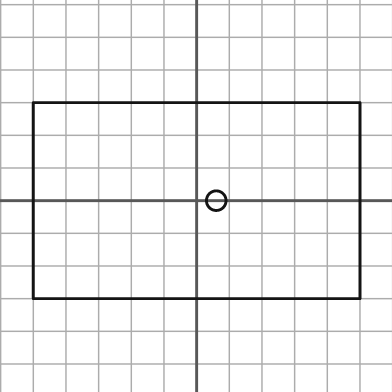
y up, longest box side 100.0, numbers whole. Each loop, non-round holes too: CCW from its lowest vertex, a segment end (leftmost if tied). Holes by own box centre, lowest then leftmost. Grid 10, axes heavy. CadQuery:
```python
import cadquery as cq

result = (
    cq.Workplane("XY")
    .moveTo(-50.0, -30.0)
    .lineTo(50.0, -30.0)
    .lineTo(50.0, 30.0)
    .lineTo(-50.0, 30.0)
    .close()
    .moveTo(6.0, 0.0)
    .circle(3.0)
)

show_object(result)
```